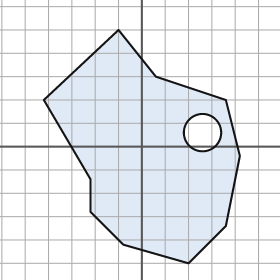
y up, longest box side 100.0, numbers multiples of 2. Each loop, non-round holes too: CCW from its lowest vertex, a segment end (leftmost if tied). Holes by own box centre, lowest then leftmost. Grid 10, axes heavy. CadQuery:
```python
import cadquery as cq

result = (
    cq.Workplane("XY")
    .moveTo(20.0, -50.0)
    .lineTo(36.0, -34.0)
    .lineTo(42.0, -4.0)
    .lineTo(36.0, 20.0)
    .lineTo(6.0, 30.0)
    .lineTo(-10.0, 50.0)
    .lineTo(-42.0, 20.0)
    .lineTo(-22.0, -14.0)
    .lineTo(-22.0, -28.0)
    .lineTo(-8.0, -42.0)
    .close()
    .moveTo(26.0, 6.0)
    .circle(8.0)
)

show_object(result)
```